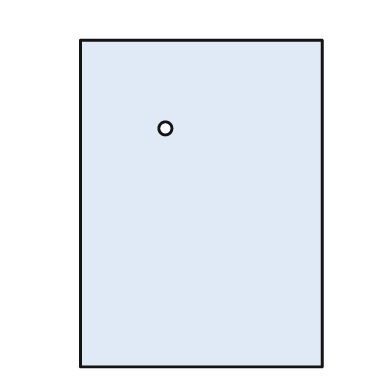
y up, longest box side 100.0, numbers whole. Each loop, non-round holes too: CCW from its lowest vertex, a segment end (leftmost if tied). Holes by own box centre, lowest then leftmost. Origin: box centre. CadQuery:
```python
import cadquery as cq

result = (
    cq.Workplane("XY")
    .moveTo(-37.0, -50.0)
    .lineTo(37.0, -50.0)
    .lineTo(37.0, 50.0)
    .lineTo(-37.0, 50.0)
    .close()
    .moveTo(-11.0, 23.0)
    .circle(2.0)
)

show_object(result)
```